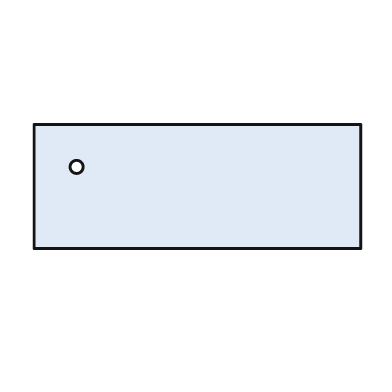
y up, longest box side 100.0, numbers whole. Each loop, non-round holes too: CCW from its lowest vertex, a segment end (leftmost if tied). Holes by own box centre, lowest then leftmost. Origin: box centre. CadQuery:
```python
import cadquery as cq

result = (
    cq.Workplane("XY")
    .moveTo(-50.0, -19.0)
    .lineTo(50.0, -19.0)
    .lineTo(50.0, 19.0)
    .lineTo(-50.0, 19.0)
    .close()
    .moveTo(-37.0, 6.0)
    .circle(2.0)
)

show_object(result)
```